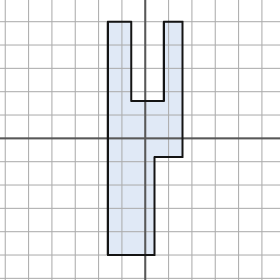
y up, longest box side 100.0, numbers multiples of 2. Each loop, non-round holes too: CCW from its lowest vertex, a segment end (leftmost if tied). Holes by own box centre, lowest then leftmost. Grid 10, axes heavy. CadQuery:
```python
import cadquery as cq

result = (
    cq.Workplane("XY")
    .moveTo(-16.0, -50.0)
    .lineTo(4.0, -50.0)
    .lineTo(4.0, -8.0)
    .lineTo(16.0, -8.0)
    .lineTo(16.0, 50.0)
    .lineTo(8.0, 50.0)
    .lineTo(8.0, 16.0)
    .lineTo(-6.0, 16.0)
    .lineTo(-6.0, 50.0)
    .lineTo(-16.0, 50.0)
    .close()
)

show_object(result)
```